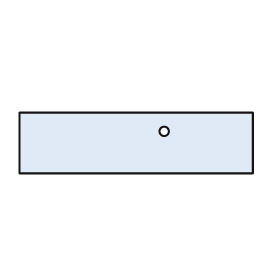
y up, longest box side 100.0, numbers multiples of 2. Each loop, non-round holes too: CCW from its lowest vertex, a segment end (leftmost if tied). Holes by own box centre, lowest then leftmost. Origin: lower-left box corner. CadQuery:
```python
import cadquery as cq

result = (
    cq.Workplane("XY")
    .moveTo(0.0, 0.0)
    .lineTo(100.0, 0.0)
    .lineTo(100.0, 26.0)
    .lineTo(0.0, 26.0)
    .close()
    .moveTo(62.0, 18.0)
    .circle(2.0)
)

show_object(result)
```